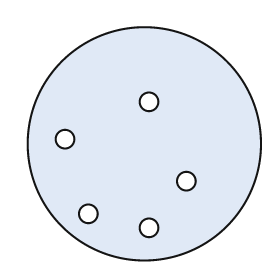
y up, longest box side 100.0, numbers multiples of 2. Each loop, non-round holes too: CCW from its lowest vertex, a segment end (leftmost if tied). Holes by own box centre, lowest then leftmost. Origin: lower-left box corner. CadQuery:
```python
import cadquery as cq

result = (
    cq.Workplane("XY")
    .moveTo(50.0, 50.0)
    .circle(50.0)
    .moveTo(52.0, 14.0)
    .circle(4.0)
    .moveTo(26.0, 20.0)
    .circle(4.0)
    .moveTo(68.0, 34.0)
    .circle(4.0)
    .moveTo(16.0, 52.0)
    .circle(4.0)
    .moveTo(52.0, 68.0)
    .circle(4.0)
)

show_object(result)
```